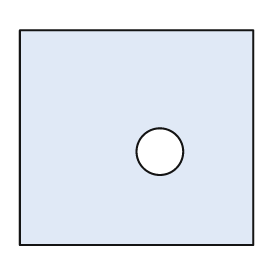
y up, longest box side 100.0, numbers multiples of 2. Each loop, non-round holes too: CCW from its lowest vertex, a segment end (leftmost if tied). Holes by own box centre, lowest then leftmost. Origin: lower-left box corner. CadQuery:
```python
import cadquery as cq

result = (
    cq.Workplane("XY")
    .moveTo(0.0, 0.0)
    .lineTo(100.0, 0.0)
    .lineTo(100.0, 92.0)
    .lineTo(0.0, 92.0)
    .close()
    .moveTo(60.0, 40.0)
    .circle(10.0)
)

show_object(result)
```